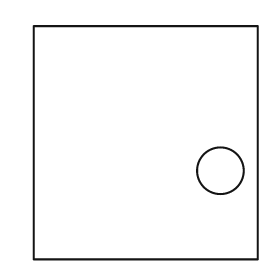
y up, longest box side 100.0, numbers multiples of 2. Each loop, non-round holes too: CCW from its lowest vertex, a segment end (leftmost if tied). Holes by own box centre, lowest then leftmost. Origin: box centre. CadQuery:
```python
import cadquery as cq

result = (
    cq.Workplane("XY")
    .moveTo(-48.0, -50.0)
    .lineTo(48.0, -50.0)
    .lineTo(48.0, 50.0)
    .lineTo(-48.0, 50.0)
    .close()
    .moveTo(32.0, -12.0)
    .circle(10.0)
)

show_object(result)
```